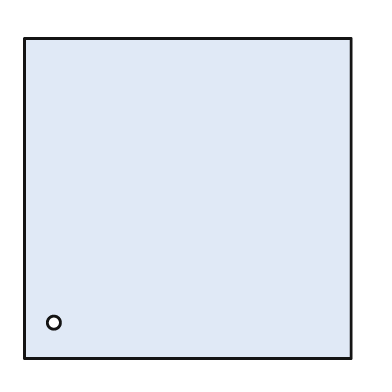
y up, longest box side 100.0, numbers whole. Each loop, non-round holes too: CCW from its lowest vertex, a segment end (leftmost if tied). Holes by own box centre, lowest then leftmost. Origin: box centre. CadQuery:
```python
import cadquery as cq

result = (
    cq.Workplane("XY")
    .moveTo(-50.0, -49.0)
    .lineTo(50.0, -49.0)
    .lineTo(50.0, 49.0)
    .lineTo(-50.0, 49.0)
    .close()
    .moveTo(-41.0, -38.0)
    .circle(2.0)
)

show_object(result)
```